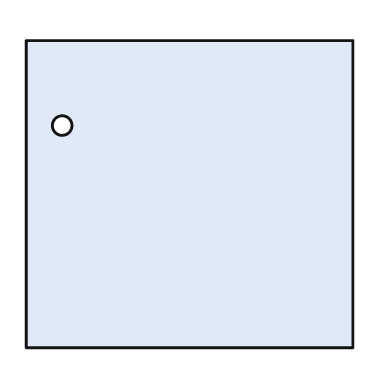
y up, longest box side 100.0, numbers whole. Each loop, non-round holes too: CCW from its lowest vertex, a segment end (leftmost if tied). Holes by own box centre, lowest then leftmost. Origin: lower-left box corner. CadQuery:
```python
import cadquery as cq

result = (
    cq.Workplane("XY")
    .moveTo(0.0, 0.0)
    .lineTo(100.0, 0.0)
    .lineTo(100.0, 94.0)
    .lineTo(0.0, 94.0)
    .close()
    .moveTo(11.0, 68.0)
    .circle(3.0)
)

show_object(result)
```